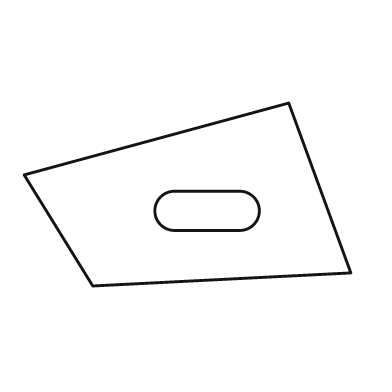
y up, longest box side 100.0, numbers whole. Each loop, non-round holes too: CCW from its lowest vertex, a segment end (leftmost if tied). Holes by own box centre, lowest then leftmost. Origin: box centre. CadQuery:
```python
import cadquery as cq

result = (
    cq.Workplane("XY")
    .moveTo(-29.0, -28.0)
    .lineTo(50.0, -24.0)
    .lineTo(31.0, 28.0)
    .lineTo(-50.0, 6.0)
    .close()
    .moveTo(-4.0, -11.0)
    .lineTo(16.0, -11.0)
    .threePointArc((22.0, -5.0), (16.0, 1.0))
    .lineTo(-4.0, 1.0)
    .threePointArc((-10.0, -5.0), (-4.0, -11.0))
    .close()
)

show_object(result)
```